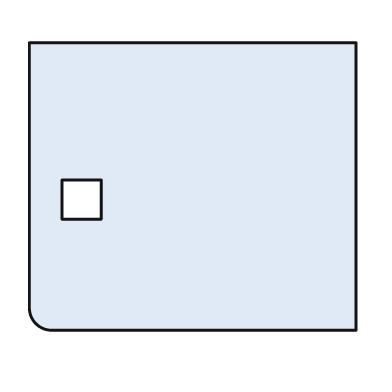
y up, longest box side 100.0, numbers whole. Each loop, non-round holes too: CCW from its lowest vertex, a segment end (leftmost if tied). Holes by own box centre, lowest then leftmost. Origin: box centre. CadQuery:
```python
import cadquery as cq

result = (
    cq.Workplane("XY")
    .moveTo(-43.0, -44.0)
    .lineTo(50.0, -44.0)
    .lineTo(50.0, 44.0)
    .lineTo(-50.0, 44.0)
    .lineTo(-50.0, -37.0)
    .threePointArc((-48.0, -42.0), (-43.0, -44.0))
    .close()
    .moveTo(-40.0, -10.0)
    .lineTo(-28.0, -10.0)
    .lineTo(-28.0, 2.0)
    .lineTo(-40.0, 2.0)
    .close()
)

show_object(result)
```